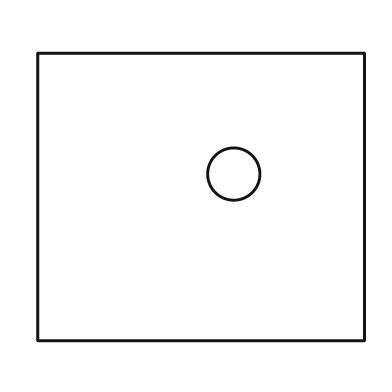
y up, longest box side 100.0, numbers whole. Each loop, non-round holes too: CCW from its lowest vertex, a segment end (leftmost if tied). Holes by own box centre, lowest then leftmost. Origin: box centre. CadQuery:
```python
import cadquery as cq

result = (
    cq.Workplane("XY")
    .moveTo(-50.0, -44.0)
    .lineTo(50.0, -44.0)
    .lineTo(50.0, 44.0)
    .lineTo(-50.0, 44.0)
    .close()
    .moveTo(10.0, 7.0)
    .circle(8.0)
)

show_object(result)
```